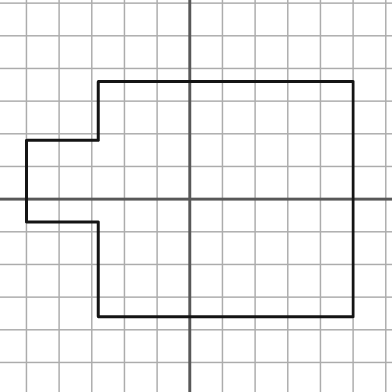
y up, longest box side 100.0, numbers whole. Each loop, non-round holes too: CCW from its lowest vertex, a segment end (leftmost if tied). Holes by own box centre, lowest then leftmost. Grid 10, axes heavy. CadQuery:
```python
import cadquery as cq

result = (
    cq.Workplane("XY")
    .moveTo(-28.0, -36.0)
    .lineTo(50.0, -36.0)
    .lineTo(50.0, 36.0)
    .lineTo(-28.0, 36.0)
    .lineTo(-28.0, 18.0)
    .lineTo(-50.0, 18.0)
    .lineTo(-50.0, -7.0)
    .lineTo(-28.0, -7.0)
    .close()
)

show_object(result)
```